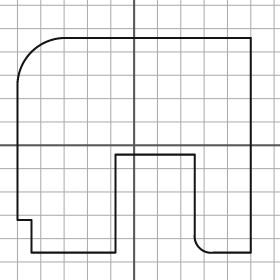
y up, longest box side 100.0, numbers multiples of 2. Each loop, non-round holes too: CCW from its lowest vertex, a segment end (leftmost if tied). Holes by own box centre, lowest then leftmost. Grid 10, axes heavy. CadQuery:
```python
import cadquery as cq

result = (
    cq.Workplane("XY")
    .moveTo(-44.0, -46.0)
    .lineTo(-8.0, -46.0)
    .lineTo(-8.0, -4.0)
    .lineTo(26.0, -4.0)
    .lineTo(26.0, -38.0)
    .threePointArc((28.0, -44.0), (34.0, -46.0))
    .lineTo(50.0, -46.0)
    .lineTo(50.0, 46.0)
    .lineTo(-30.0, 46.0)
    .threePointArc((-44.0, 40.0), (-50.0, 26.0))
    .lineTo(-50.0, -32.0)
    .lineTo(-44.0, -32.0)
    .close()
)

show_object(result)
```